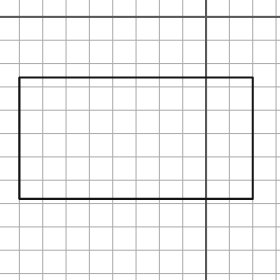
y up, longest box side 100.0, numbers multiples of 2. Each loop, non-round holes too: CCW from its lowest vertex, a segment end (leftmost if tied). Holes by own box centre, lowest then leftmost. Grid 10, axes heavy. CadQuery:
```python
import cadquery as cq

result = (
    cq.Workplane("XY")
    .moveTo(-80.0, -78.0)
    .lineTo(20.0, -78.0)
    .lineTo(20.0, -26.0)
    .lineTo(-80.0, -26.0)
    .close()
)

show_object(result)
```